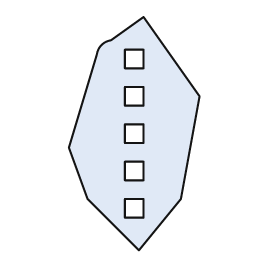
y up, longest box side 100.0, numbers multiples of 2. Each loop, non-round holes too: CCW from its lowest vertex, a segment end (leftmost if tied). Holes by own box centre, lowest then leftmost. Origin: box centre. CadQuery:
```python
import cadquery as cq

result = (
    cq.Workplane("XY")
    .moveTo(2.0, -50.0)
    .lineTo(20.0, -28.0)
    .lineTo(28.0, 16.0)
    .lineTo(4.0, 50.0)
    .lineTo(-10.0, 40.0)
    .threePointArc((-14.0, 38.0), (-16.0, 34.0))
    .lineTo(-28.0, -6.0)
    .lineTo(-20.0, -28.0)
    .close()
    .moveTo(-4.0, -36.0)
    .lineTo(4.0, -36.0)
    .lineTo(4.0, -28.0)
    .lineTo(-4.0, -28.0)
    .close()
    .moveTo(-4.0, -20.0)
    .lineTo(4.0, -20.0)
    .lineTo(4.0, -12.0)
    .lineTo(-4.0, -12.0)
    .close()
    .moveTo(-4.0, -4.0)
    .lineTo(4.0, -4.0)
    .lineTo(4.0, 4.0)
    .lineTo(-4.0, 4.0)
    .close()
    .moveTo(-4.0, 12.0)
    .lineTo(4.0, 12.0)
    .lineTo(4.0, 20.0)
    .lineTo(-4.0, 20.0)
    .close()
    .moveTo(-4.0, 28.0)
    .lineTo(4.0, 28.0)
    .lineTo(4.0, 36.0)
    .lineTo(-4.0, 36.0)
    .close()
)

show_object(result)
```